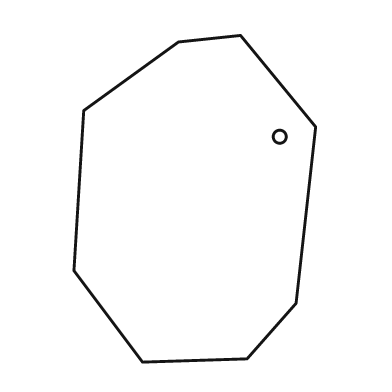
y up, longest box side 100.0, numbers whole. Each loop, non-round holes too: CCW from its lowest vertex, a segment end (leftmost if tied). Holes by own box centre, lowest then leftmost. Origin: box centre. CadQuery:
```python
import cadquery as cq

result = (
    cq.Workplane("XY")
    .moveTo(-16.0, -50.0)
    .lineTo(16.0, -49.0)
    .lineTo(31.0, -32.0)
    .lineTo(37.0, 22.0)
    .lineTo(14.0, 50.0)
    .lineTo(-5.0, 48.0)
    .lineTo(-34.0, 27.0)
    .lineTo(-37.0, -22.0)
    .close()
    .moveTo(26.0, 19.0)
    .circle(2.0)
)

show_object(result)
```